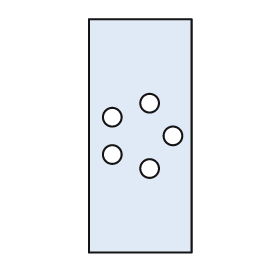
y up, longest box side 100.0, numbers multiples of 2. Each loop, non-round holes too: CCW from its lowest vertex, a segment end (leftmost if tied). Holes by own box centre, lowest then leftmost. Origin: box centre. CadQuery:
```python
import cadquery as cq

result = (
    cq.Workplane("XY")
    .moveTo(-22.0, -50.0)
    .lineTo(22.0, -50.0)
    .lineTo(22.0, 50.0)
    .lineTo(-22.0, 50.0)
    .close()
    .moveTo(4.0, -14.0)
    .circle(4.0)
    .moveTo(-12.0, -8.0)
    .circle(4.0)
    .moveTo(14.0, 0.0)
    .circle(4.0)
    .moveTo(-12.0, 8.0)
    .circle(4.0)
    .moveTo(4.0, 14.0)
    .circle(4.0)
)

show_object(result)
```